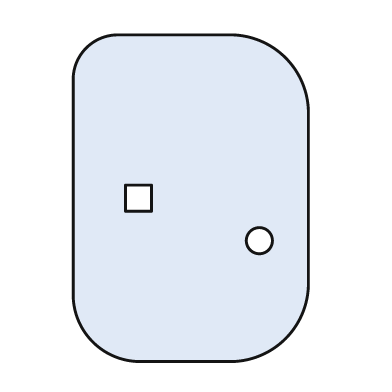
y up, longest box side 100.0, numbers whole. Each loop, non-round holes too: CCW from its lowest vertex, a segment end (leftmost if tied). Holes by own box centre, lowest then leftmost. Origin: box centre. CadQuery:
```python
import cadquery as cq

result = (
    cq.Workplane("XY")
    .moveTo(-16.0, -50.0)
    .lineTo(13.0, -50.0)
    .threePointArc((29.0, -43.0), (36.0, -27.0))
    .lineTo(36.0, 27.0)
    .threePointArc((29.0, 43.0), (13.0, 50.0))
    .lineTo(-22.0, 50.0)
    .threePointArc((-32.0, 46.0), (-36.0, 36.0))
    .lineTo(-36.0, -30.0)
    .threePointArc((-30.0, -44.0), (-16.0, -50.0))
    .close()
    .moveTo(21.0, -13.0)
    .circle(4.0)
    .moveTo(-20.0, -4.0)
    .lineTo(-12.0, -4.0)
    .lineTo(-12.0, 4.0)
    .lineTo(-20.0, 4.0)
    .close()
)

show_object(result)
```